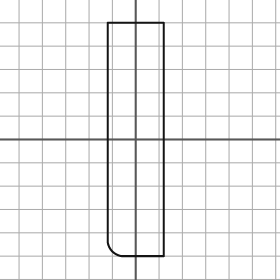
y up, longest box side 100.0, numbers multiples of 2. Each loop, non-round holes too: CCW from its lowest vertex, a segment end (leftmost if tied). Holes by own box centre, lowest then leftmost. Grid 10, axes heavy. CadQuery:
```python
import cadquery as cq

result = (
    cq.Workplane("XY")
    .moveTo(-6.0, -50.0)
    .lineTo(12.0, -50.0)
    .lineTo(12.0, 50.0)
    .lineTo(-12.0, 50.0)
    .lineTo(-12.0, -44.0)
    .threePointArc((-10.0, -48.0), (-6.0, -50.0))
    .close()
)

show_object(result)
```